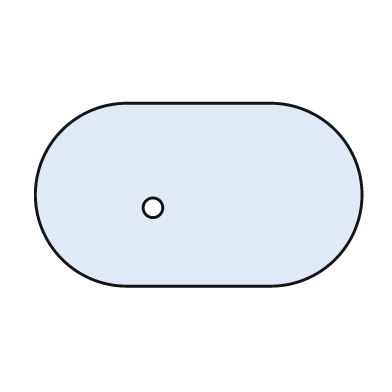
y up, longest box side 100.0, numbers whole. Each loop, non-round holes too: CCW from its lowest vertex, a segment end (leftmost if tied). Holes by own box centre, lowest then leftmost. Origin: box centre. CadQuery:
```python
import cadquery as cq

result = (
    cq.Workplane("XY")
    .moveTo(-22.0, -28.0)
    .lineTo(22.0, -28.0)
    .threePointArc((50.0, 0.0), (22.0, 28.0))
    .lineTo(-22.0, 28.0)
    .threePointArc((-50.0, 0.0), (-22.0, -28.0))
    .close()
    .moveTo(-14.0, -4.0)
    .circle(3.0)
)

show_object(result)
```